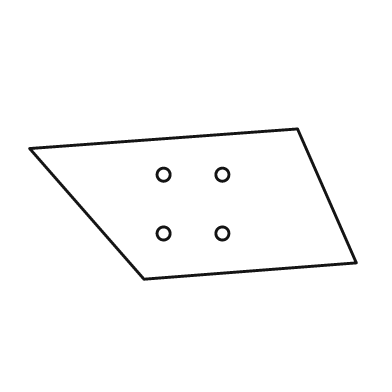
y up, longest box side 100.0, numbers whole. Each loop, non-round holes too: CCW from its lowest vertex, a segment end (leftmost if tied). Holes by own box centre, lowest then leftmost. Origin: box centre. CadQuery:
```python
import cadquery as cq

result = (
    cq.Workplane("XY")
    .moveTo(-15.0, -23.0)
    .lineTo(50.0, -18.0)
    .lineTo(32.0, 23.0)
    .lineTo(-50.0, 17.0)
    .close()
    .moveTo(-9.0, -9.0)
    .circle(2.0)
    .moveTo(9.0, -9.0)
    .circle(2.0)
    .moveTo(-9.0, 9.0)
    .circle(2.0)
    .moveTo(9.0, 9.0)
    .circle(2.0)
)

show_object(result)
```